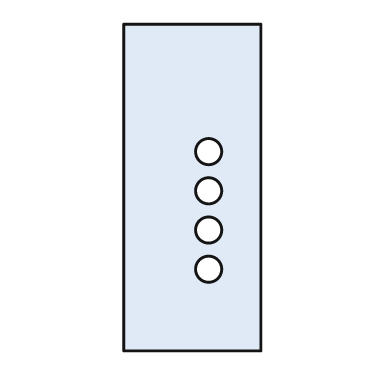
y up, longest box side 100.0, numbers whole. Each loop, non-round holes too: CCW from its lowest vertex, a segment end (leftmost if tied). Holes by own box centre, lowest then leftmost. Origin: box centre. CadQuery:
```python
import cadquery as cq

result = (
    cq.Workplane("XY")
    .moveTo(-21.0, -50.0)
    .lineTo(21.0, -50.0)
    .lineTo(21.0, 50.0)
    .lineTo(-21.0, 50.0)
    .close()
    .moveTo(5.0, -25.0)
    .circle(4.0)
    .moveTo(5.0, -13.0)
    .circle(4.0)
    .moveTo(5.0, -1.0)
    .circle(4.0)
    .moveTo(5.0, 11.0)
    .circle(4.0)
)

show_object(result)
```